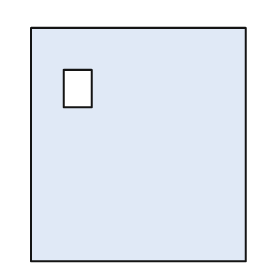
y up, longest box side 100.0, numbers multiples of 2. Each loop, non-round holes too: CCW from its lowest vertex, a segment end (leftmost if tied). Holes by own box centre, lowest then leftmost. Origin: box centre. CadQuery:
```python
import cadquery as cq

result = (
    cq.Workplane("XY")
    .moveTo(-46.0, -50.0)
    .lineTo(46.0, -50.0)
    .lineTo(46.0, 50.0)
    .lineTo(-46.0, 50.0)
    .close()
    .moveTo(-32.0, 16.0)
    .lineTo(-20.0, 16.0)
    .lineTo(-20.0, 32.0)
    .lineTo(-32.0, 32.0)
    .close()
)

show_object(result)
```